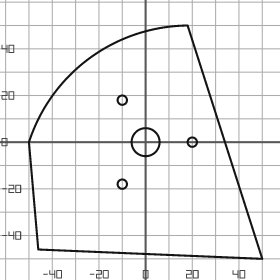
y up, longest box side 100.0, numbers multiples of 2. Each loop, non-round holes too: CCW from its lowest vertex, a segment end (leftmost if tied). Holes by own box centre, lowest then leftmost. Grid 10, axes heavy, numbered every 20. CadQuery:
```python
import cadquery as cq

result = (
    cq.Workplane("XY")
    .moveTo(50.0, -50.0)
    .lineTo(18.0, 50.0)
    .threePointArc((-24.0, 36.0), (-50.0, 0.0))
    .lineTo(-46.0, -46.0)
    .close()
    .moveTo(-10.0, -18.0)
    .circle(2.0)
    .moveTo(0.0, 0.0)
    .circle(6.0)
    .moveTo(20.0, 0.0)
    .circle(2.0)
    .moveTo(-10.0, 18.0)
    .circle(2.0)
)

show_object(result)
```